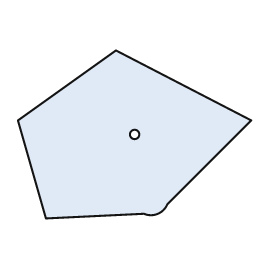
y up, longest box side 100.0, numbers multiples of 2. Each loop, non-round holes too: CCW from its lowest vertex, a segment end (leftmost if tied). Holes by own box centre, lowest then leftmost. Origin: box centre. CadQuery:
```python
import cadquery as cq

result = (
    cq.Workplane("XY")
    .moveTo(-38.0, -36.0)
    .lineTo(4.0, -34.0)
    .threePointArc((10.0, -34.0), (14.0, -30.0))
    .lineTo(50.0, 6.0)
    .lineTo(-8.0, 36.0)
    .lineTo(-50.0, 6.0)
    .close()
    .moveTo(0.0, 0.0)
    .circle(2.0)
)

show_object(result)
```